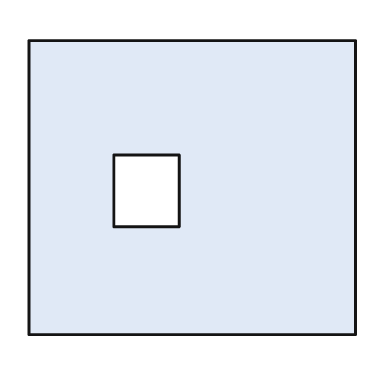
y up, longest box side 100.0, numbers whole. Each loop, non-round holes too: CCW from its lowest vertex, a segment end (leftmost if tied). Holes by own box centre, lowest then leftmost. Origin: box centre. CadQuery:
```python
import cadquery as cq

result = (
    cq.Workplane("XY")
    .moveTo(-50.0, -45.0)
    .lineTo(50.0, -45.0)
    .lineTo(50.0, 45.0)
    .lineTo(-50.0, 45.0)
    .close()
    .moveTo(-24.0, -12.0)
    .lineTo(-4.0, -12.0)
    .lineTo(-4.0, 10.0)
    .lineTo(-24.0, 10.0)
    .close()
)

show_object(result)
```